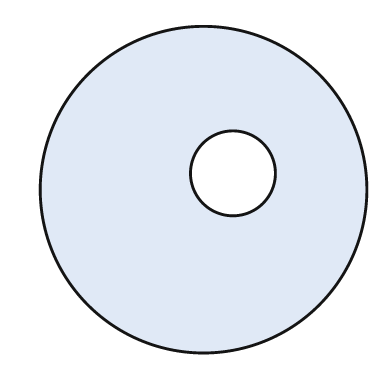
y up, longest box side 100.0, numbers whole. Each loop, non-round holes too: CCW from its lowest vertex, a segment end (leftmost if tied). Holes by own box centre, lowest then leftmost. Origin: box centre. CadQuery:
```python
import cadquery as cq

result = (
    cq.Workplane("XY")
    .moveTo(0.0, 0.0)
    .circle(50.0)
    .moveTo(9.0, 5.0)
    .circle(13.0)
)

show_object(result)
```